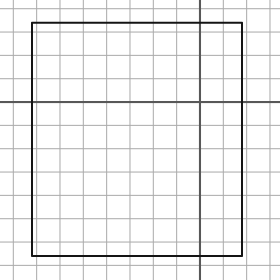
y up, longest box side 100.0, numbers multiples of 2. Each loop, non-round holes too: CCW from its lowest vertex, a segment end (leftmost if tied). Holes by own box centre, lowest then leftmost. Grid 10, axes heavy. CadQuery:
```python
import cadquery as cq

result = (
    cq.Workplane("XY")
    .moveTo(-72.0, -66.0)
    .lineTo(18.0, -66.0)
    .lineTo(18.0, 34.0)
    .lineTo(-72.0, 34.0)
    .close()
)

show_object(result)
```